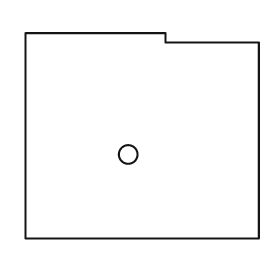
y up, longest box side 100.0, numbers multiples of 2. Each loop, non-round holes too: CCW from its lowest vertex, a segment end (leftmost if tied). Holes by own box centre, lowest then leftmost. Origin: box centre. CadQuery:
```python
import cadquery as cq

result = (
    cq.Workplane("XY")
    .moveTo(-50.0, -44.0)
    .lineTo(50.0, -44.0)
    .lineTo(50.0, 40.0)
    .lineTo(10.0, 40.0)
    .lineTo(10.0, 44.0)
    .lineTo(-50.0, 44.0)
    .close()
    .moveTo(-6.0, -8.0)
    .circle(4.0)
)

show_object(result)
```